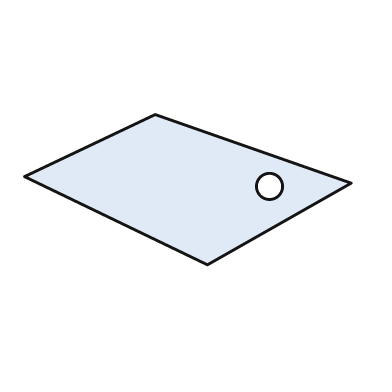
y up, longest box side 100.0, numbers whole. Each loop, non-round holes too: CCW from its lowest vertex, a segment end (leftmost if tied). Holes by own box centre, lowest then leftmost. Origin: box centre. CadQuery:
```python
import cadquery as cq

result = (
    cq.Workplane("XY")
    .moveTo(6.0, -23.0)
    .lineTo(50.0, 2.0)
    .lineTo(-10.0, 23.0)
    .lineTo(-50.0, 4.0)
    .close()
    .moveTo(25.0, 1.0)
    .circle(4.0)
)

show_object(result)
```